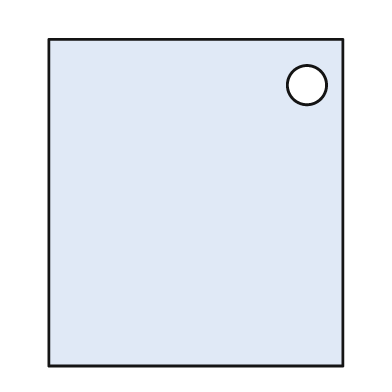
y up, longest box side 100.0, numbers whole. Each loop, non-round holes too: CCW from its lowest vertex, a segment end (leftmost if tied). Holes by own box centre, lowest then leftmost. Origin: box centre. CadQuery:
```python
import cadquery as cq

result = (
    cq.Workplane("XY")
    .moveTo(-45.0, -50.0)
    .lineTo(45.0, -50.0)
    .lineTo(45.0, 50.0)
    .lineTo(-45.0, 50.0)
    .close()
    .moveTo(34.0, 36.0)
    .circle(6.0)
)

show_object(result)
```